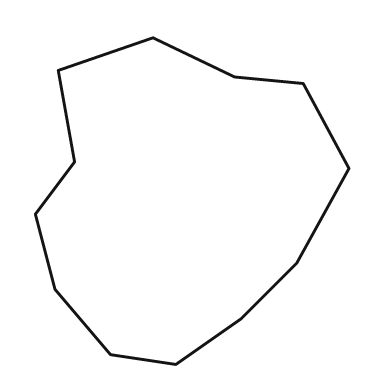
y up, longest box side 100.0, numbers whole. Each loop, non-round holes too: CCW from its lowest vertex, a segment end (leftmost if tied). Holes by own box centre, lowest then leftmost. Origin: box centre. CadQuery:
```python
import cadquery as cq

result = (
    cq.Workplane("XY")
    .moveTo(-5.0, -50.0)
    .lineTo(15.0, -36.0)
    .lineTo(32.0, -19.0)
    .lineTo(48.0, 10.0)
    .lineTo(34.0, 36.0)
    .lineTo(13.0, 38.0)
    .lineTo(-12.0, 50.0)
    .lineTo(-41.0, 40.0)
    .lineTo(-36.0, 12.0)
    .lineTo(-48.0, -4.0)
    .lineTo(-42.0, -27.0)
    .lineTo(-25.0, -47.0)
    .close()
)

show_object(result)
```